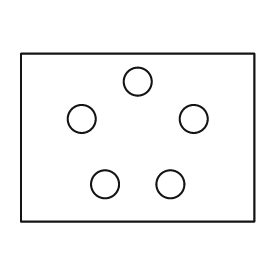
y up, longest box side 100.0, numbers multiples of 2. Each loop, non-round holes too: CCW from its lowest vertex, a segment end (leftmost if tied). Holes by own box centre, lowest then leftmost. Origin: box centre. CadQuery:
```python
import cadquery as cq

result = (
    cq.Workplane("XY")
    .moveTo(-50.0, -36.0)
    .lineTo(50.0, -36.0)
    .lineTo(50.0, 36.0)
    .lineTo(-50.0, 36.0)
    .close()
    .moveTo(-14.0, -20.0)
    .circle(6.0)
    .moveTo(14.0, -20.0)
    .circle(6.0)
    .moveTo(-24.0, 8.0)
    .circle(6.0)
    .moveTo(24.0, 8.0)
    .circle(6.0)
    .moveTo(0.0, 24.0)
    .circle(6.0)
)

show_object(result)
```